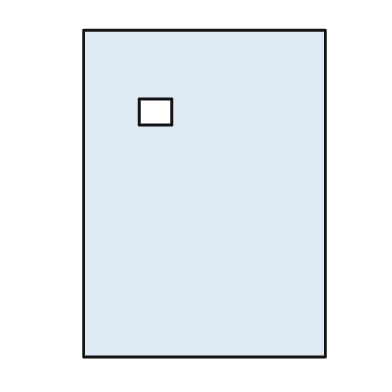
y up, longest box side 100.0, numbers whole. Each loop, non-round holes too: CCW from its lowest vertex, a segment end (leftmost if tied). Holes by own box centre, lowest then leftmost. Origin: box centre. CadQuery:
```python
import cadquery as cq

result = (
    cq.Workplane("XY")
    .moveTo(-37.0, -50.0)
    .lineTo(37.0, -50.0)
    .lineTo(37.0, 50.0)
    .lineTo(-37.0, 50.0)
    .close()
    .moveTo(-20.0, 21.0)
    .lineTo(-10.0, 21.0)
    .lineTo(-10.0, 29.0)
    .lineTo(-20.0, 29.0)
    .close()
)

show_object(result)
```